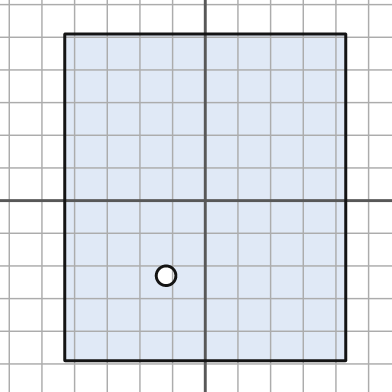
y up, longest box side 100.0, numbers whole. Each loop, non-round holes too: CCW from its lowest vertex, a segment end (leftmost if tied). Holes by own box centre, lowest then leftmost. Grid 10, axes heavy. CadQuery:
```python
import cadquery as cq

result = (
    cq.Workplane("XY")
    .moveTo(-43.0, -49.0)
    .lineTo(43.0, -49.0)
    .lineTo(43.0, 51.0)
    .lineTo(-43.0, 51.0)
    .close()
    .moveTo(-12.0, -23.0)
    .circle(3.0)
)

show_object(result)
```